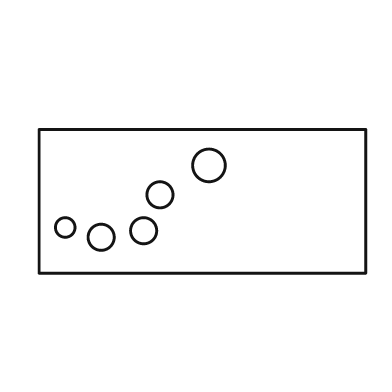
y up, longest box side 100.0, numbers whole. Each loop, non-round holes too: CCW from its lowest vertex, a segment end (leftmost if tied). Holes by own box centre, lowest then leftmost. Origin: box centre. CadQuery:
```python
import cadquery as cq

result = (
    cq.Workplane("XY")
    .moveTo(-50.0, -22.0)
    .lineTo(50.0, -22.0)
    .lineTo(50.0, 22.0)
    .lineTo(-50.0, 22.0)
    .close()
    .moveTo(-31.0, -11.0)
    .circle(4.0)
    .moveTo(-18.0, -9.0)
    .circle(4.0)
    .moveTo(-42.0, -8.0)
    .circle(3.0)
    .moveTo(-13.0, 2.0)
    .circle(4.0)
    .moveTo(2.0, 11.0)
    .circle(5.0)
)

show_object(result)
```